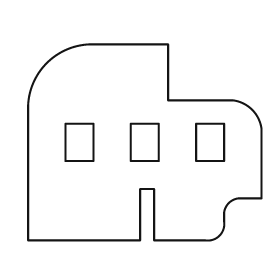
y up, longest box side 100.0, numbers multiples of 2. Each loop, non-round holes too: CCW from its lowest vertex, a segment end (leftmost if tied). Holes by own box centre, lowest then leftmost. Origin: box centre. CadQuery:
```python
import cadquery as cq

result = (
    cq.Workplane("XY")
    .moveTo(-50.0, -42.0)
    .lineTo(-2.0, -42.0)
    .lineTo(-2.0, -20.0)
    .lineTo(4.0, -20.0)
    .lineTo(4.0, -42.0)
    .lineTo(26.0, -42.0)
    .threePointArc((32.0, -40.0), (34.0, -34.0))
    .lineTo(34.0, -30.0)
    .threePointArc((36.0, -26.0), (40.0, -24.0))
    .lineTo(50.0, -24.0)
    .lineTo(50.0, 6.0)
    .threePointArc((46.0, 14.0), (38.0, 18.0))
    .lineTo(10.0, 18.0)
    .lineTo(10.0, 42.0)
    .lineTo(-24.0, 42.0)
    .threePointArc((-42.0, 34.0), (-50.0, 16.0))
    .close()
    .moveTo(-34.0, -8.0)
    .lineTo(-22.0, -8.0)
    .lineTo(-22.0, 8.0)
    .lineTo(-34.0, 8.0)
    .close()
    .moveTo(-6.0, -8.0)
    .lineTo(6.0, -8.0)
    .lineTo(6.0, 8.0)
    .lineTo(-6.0, 8.0)
    .close()
    .moveTo(22.0, -8.0)
    .lineTo(34.0, -8.0)
    .lineTo(34.0, 8.0)
    .lineTo(22.0, 8.0)
    .close()
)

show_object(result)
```